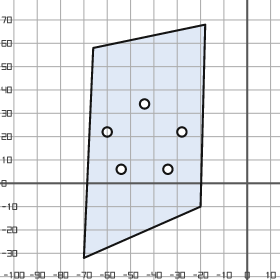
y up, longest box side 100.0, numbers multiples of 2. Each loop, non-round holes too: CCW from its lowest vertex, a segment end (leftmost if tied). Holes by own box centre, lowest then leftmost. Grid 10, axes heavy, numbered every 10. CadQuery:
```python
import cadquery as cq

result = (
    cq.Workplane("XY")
    .moveTo(-70.0, -32.0)
    .lineTo(-20.0, -10.0)
    .lineTo(-18.0, 68.0)
    .lineTo(-66.0, 58.0)
    .close()
    .moveTo(-54.0, 6.0)
    .circle(2.0)
    .moveTo(-34.0, 6.0)
    .circle(2.0)
    .moveTo(-60.0, 22.0)
    .circle(2.0)
    .moveTo(-28.0, 22.0)
    .circle(2.0)
    .moveTo(-44.0, 34.0)
    .circle(2.0)
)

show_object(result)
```